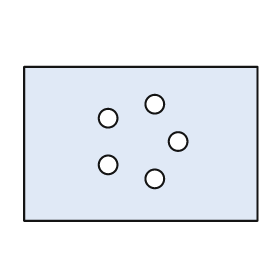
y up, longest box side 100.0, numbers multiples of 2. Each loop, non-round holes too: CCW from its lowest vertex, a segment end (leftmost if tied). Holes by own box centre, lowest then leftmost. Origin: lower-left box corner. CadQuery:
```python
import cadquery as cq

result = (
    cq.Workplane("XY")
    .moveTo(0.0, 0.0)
    .lineTo(100.0, 0.0)
    .lineTo(100.0, 66.0)
    .lineTo(0.0, 66.0)
    .close()
    .moveTo(56.0, 18.0)
    .circle(4.0)
    .moveTo(36.0, 24.0)
    .circle(4.0)
    .moveTo(66.0, 34.0)
    .circle(4.0)
    .moveTo(36.0, 44.0)
    .circle(4.0)
    .moveTo(56.0, 50.0)
    .circle(4.0)
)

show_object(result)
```